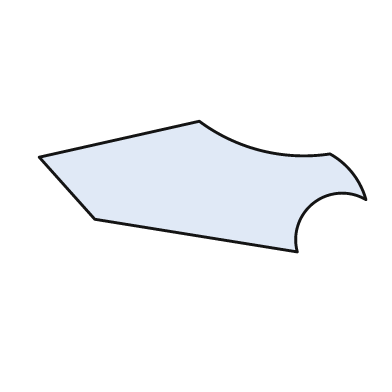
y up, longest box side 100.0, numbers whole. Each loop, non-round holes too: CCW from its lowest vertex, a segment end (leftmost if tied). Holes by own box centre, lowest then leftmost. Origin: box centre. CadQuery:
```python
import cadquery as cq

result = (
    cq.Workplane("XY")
    .moveTo(29.0, -20.0)
    .threePointArc((34.0, -5.0), (50.0, -4.0))
    .threePointArc((46.0, 4.0), (39.0, 10.0))
    .threePointArc((18.0, 11.0), (-1.0, 20.0))
    .lineTo(-50.0, 9.0)
    .lineTo(-33.0, -10.0)
    .close()
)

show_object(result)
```